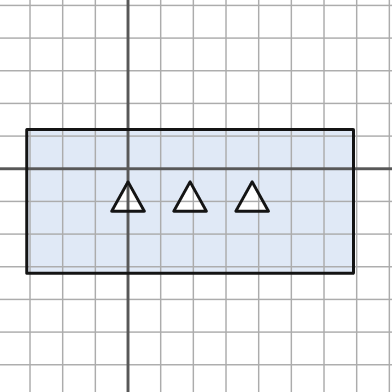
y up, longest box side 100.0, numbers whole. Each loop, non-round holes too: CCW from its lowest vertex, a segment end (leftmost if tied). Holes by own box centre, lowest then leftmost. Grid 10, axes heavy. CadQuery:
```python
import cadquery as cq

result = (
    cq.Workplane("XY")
    .moveTo(-31.0, -32.0)
    .lineTo(69.0, -32.0)
    .lineTo(69.0, 12.0)
    .lineTo(-31.0, 12.0)
    .close()
    .moveTo(-5.0, -13.0)
    .lineTo(5.0, -13.0)
    .lineTo(0.0, -4.0)
    .close()
    .moveTo(14.0, -13.0)
    .lineTo(24.0, -13.0)
    .lineTo(19.0, -4.0)
    .close()
    .moveTo(33.0, -13.0)
    .lineTo(43.0, -13.0)
    .lineTo(38.0, -4.0)
    .close()
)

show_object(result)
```